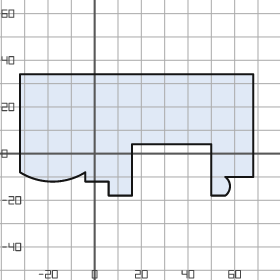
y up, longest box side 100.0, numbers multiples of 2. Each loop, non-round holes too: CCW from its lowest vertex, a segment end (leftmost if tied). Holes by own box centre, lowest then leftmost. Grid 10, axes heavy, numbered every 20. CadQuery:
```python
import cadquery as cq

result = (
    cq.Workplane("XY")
    .moveTo(6.0, -18.0)
    .lineTo(16.0, -18.0)
    .lineTo(16.0, 4.0)
    .lineTo(50.0, 4.0)
    .lineTo(50.0, -18.0)
    .lineTo(56.0, -18.0)
    .threePointArc((58.0, -14.0), (56.0, -10.0))
    .lineTo(68.0, -10.0)
    .lineTo(68.0, 34.0)
    .lineTo(-32.0, 34.0)
    .lineTo(-32.0, -8.0)
    .threePointArc((-18.0, -12.0), (-4.0, -8.0))
    .lineTo(-4.0, -12.0)
    .lineTo(6.0, -12.0)
    .close()
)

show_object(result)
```